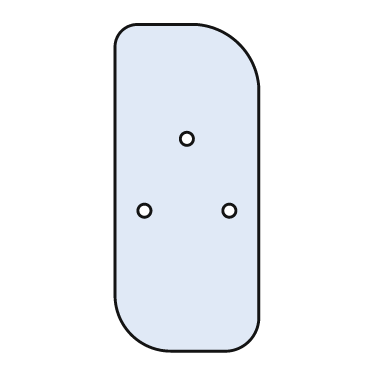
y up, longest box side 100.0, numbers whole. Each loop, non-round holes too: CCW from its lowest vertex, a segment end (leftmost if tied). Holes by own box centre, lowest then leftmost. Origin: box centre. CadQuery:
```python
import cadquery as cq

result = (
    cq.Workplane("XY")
    .moveTo(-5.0, -50.0)
    .lineTo(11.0, -50.0)
    .threePointArc((19.0, -47.0), (22.0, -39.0))
    .lineTo(22.0, 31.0)
    .threePointArc((16.0, 44.0), (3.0, 50.0))
    .lineTo(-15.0, 50.0)
    .threePointArc((-20.0, 48.0), (-22.0, 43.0))
    .lineTo(-22.0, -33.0)
    .threePointArc((-17.0, -45.0), (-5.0, -50.0))
    .close()
    .moveTo(-13.0, -7.0)
    .circle(2.0)
    .moveTo(13.0, -7.0)
    .circle(2.0)
    .moveTo(0.0, 15.0)
    .circle(2.0)
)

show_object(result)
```